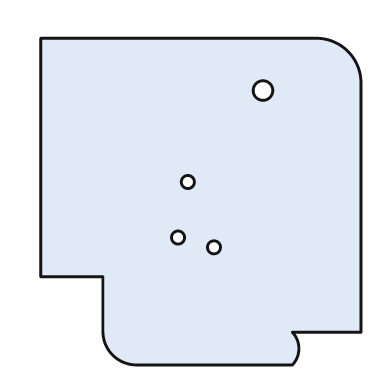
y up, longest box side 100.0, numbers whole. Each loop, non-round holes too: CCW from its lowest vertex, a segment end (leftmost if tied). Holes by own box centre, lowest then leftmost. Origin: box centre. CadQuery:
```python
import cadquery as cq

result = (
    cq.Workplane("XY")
    .moveTo(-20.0, -50.0)
    .lineTo(28.0, -50.0)
    .threePointArc((30.0, -45.0), (28.0, -40.0))
    .lineTo(49.0, -40.0)
    .lineTo(49.0, 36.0)
    .threePointArc((45.0, 46.0), (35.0, 50.0))
    .lineTo(-49.0, 50.0)
    .lineTo(-49.0, -23.0)
    .lineTo(-30.0, -23.0)
    .lineTo(-30.0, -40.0)
    .threePointArc((-27.0, -47.0), (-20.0, -50.0))
    .close()
    .moveTo(4.0, -14.0)
    .circle(2.0)
    .moveTo(-7.0, -11.0)
    .circle(2.0)
    .moveTo(-4.0, 6.0)
    .circle(2.0)
    .moveTo(19.0, 34.0)
    .circle(3.0)
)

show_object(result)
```